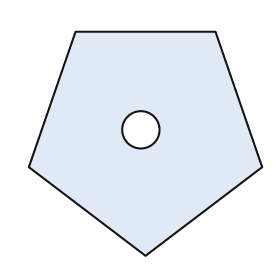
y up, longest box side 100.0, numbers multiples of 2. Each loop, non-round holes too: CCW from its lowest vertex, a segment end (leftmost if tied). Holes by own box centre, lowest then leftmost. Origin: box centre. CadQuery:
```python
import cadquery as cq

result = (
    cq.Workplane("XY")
    .moveTo(0.0, -48.0)
    .lineTo(50.0, -10.0)
    .lineTo(30.0, 48.0)
    .lineTo(-30.0, 48.0)
    .lineTo(-50.0, -10.0)
    .close()
    .moveTo(-2.0, 6.0)
    .circle(8.0)
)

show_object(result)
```